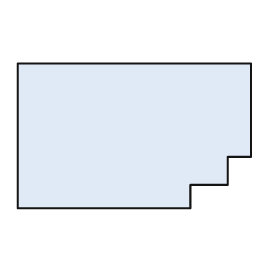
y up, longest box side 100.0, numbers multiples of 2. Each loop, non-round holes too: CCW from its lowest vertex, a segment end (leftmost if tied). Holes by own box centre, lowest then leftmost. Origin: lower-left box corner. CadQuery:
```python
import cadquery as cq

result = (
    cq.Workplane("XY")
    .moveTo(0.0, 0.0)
    .lineTo(74.0, 0.0)
    .lineTo(74.0, 10.0)
    .lineTo(90.0, 10.0)
    .lineTo(90.0, 22.0)
    .lineTo(100.0, 22.0)
    .lineTo(100.0, 62.0)
    .lineTo(0.0, 62.0)
    .close()
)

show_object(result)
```